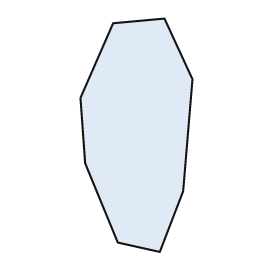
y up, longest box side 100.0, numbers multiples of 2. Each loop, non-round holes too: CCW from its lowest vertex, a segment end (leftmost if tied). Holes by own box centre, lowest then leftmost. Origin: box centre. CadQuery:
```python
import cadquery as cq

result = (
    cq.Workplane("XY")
    .moveTo(10.0, -50.0)
    .lineTo(20.0, -24.0)
    .lineTo(24.0, 24.0)
    .lineTo(12.0, 50.0)
    .lineTo(-10.0, 48.0)
    .lineTo(-24.0, 16.0)
    .lineTo(-22.0, -12.0)
    .lineTo(-8.0, -46.0)
    .close()
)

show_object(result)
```